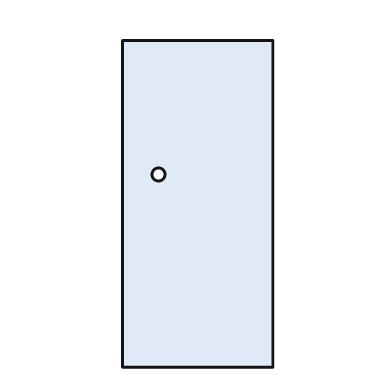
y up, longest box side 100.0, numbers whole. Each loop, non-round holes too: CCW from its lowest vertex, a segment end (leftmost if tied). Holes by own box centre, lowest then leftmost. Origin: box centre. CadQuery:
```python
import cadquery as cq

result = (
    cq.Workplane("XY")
    .moveTo(-23.0, -50.0)
    .lineTo(23.0, -50.0)
    .lineTo(23.0, 50.0)
    .lineTo(-23.0, 50.0)
    .close()
    .moveTo(-12.0, 9.0)
    .circle(2.0)
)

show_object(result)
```